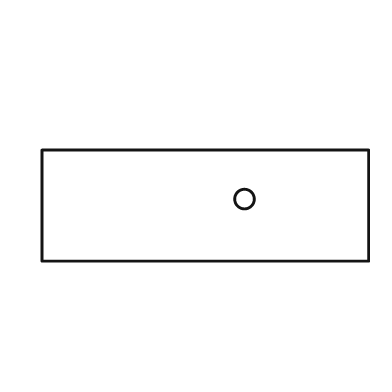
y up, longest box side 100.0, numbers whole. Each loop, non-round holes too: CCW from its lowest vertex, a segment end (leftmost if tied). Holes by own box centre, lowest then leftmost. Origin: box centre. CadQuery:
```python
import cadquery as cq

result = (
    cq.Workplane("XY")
    .moveTo(-50.0, -17.0)
    .lineTo(50.0, -17.0)
    .lineTo(50.0, 17.0)
    .lineTo(-50.0, 17.0)
    .close()
    .moveTo(12.0, 2.0)
    .circle(3.0)
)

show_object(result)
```